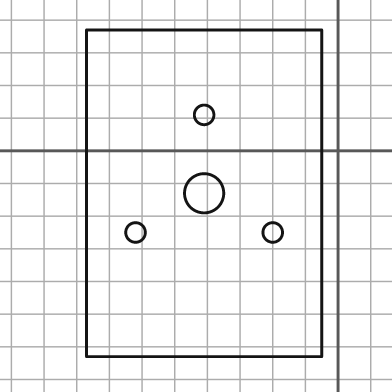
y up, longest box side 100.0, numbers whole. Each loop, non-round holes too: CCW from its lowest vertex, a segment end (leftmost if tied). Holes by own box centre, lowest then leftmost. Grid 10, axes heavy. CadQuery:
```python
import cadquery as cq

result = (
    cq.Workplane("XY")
    .moveTo(-77.0, -63.0)
    .lineTo(-5.0, -63.0)
    .lineTo(-5.0, 37.0)
    .lineTo(-77.0, 37.0)
    .close()
    .moveTo(-62.0, -25.0)
    .circle(3.0)
    .moveTo(-20.0, -25.0)
    .circle(3.0)
    .moveTo(-41.0, -13.0)
    .circle(6.0)
    .moveTo(-41.0, 11.0)
    .circle(3.0)
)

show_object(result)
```